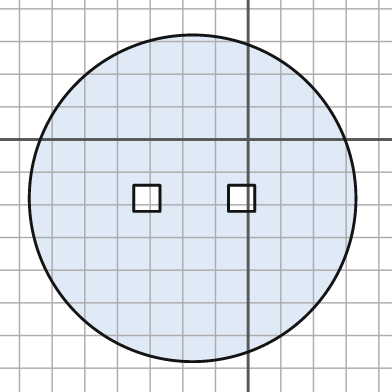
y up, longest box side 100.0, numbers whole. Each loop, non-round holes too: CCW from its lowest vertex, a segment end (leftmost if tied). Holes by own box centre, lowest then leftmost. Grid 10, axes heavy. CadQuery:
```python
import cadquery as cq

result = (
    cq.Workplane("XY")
    .moveTo(-17.0, -18.0)
    .circle(50.0)
    .moveTo(-35.0, -22.0)
    .lineTo(-27.0, -22.0)
    .lineTo(-27.0, -14.0)
    .lineTo(-35.0, -14.0)
    .close()
    .moveTo(-6.0, -22.0)
    .lineTo(2.0, -22.0)
    .lineTo(2.0, -14.0)
    .lineTo(-6.0, -14.0)
    .close()
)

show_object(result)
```